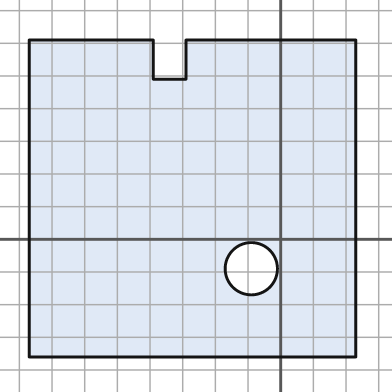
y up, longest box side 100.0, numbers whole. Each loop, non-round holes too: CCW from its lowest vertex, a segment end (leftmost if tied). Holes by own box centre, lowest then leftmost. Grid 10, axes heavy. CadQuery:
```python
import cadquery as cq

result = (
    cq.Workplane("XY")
    .moveTo(-77.0, -36.0)
    .lineTo(23.0, -36.0)
    .lineTo(23.0, 61.0)
    .lineTo(-29.0, 61.0)
    .lineTo(-29.0, 49.0)
    .lineTo(-39.0, 49.0)
    .lineTo(-39.0, 61.0)
    .lineTo(-77.0, 61.0)
    .close()
    .moveTo(-9.0, -9.0)
    .circle(8.0)
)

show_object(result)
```